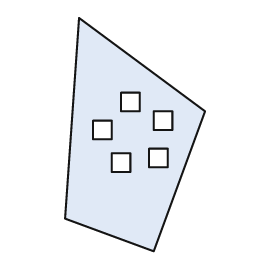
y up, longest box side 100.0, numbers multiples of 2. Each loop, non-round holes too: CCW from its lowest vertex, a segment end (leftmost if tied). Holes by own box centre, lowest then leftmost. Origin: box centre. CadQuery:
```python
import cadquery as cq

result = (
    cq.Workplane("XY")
    .moveTo(8.0, -50.0)
    .lineTo(30.0, 10.0)
    .lineTo(-24.0, 50.0)
    .lineTo(-30.0, -36.0)
    .close()
    .moveTo(-10.0, -16.0)
    .lineTo(-2.0, -16.0)
    .lineTo(-2.0, -8.0)
    .lineTo(-10.0, -8.0)
    .close()
    .moveTo(6.0, -14.0)
    .lineTo(14.0, -14.0)
    .lineTo(14.0, -6.0)
    .lineTo(6.0, -6.0)
    .close()
    .moveTo(-18.0, -2.0)
    .lineTo(-10.0, -2.0)
    .lineTo(-10.0, 6.0)
    .lineTo(-18.0, 6.0)
    .close()
    .moveTo(8.0, 2.0)
    .lineTo(16.0, 2.0)
    .lineTo(16.0, 10.0)
    .lineTo(8.0, 10.0)
    .close()
    .moveTo(-6.0, 10.0)
    .lineTo(2.0, 10.0)
    .lineTo(2.0, 18.0)
    .lineTo(-6.0, 18.0)
    .close()
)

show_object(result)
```